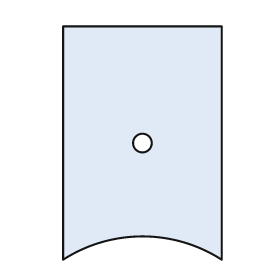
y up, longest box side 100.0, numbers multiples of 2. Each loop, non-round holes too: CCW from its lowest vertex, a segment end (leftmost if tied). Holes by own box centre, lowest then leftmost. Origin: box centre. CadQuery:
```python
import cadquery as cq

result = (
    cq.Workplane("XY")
    .moveTo(-34.0, -50.0)
    .threePointArc((0.0, -40.0), (34.0, -50.0))
    .lineTo(34.0, 50.0)
    .lineTo(-34.0, 50.0)
    .close()
    .moveTo(0.0, 0.0)
    .circle(4.0)
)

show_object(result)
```